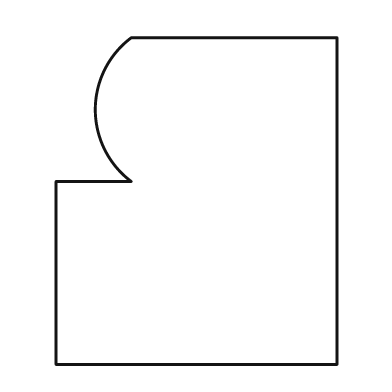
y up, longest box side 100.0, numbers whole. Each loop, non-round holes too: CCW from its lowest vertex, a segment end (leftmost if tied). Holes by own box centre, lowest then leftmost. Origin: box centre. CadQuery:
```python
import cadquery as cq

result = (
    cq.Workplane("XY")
    .moveTo(-43.0, -50.0)
    .lineTo(43.0, -50.0)
    .lineTo(43.0, 50.0)
    .lineTo(-20.0, 50.0)
    .threePointArc((-31.0, 28.0), (-20.0, 6.0))
    .lineTo(-43.0, 6.0)
    .close()
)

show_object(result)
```